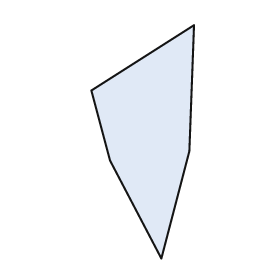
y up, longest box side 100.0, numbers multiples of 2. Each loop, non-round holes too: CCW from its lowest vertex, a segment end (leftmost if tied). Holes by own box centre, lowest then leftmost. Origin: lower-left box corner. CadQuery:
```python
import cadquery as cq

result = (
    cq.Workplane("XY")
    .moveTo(30.0, 0.0)
    .lineTo(42.0, 46.0)
    .lineTo(44.0, 100.0)
    .lineTo(0.0, 72.0)
    .lineTo(8.0, 42.0)
    .close()
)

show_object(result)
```